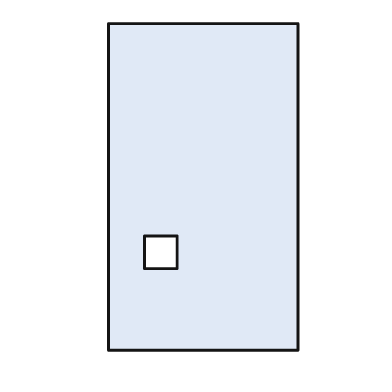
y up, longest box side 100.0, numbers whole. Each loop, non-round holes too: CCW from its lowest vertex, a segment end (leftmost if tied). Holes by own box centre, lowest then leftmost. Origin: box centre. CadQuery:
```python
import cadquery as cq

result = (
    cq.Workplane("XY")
    .moveTo(-29.0, -50.0)
    .lineTo(29.0, -50.0)
    .lineTo(29.0, 50.0)
    .lineTo(-29.0, 50.0)
    .close()
    .moveTo(-18.0, -25.0)
    .lineTo(-8.0, -25.0)
    .lineTo(-8.0, -15.0)
    .lineTo(-18.0, -15.0)
    .close()
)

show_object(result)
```